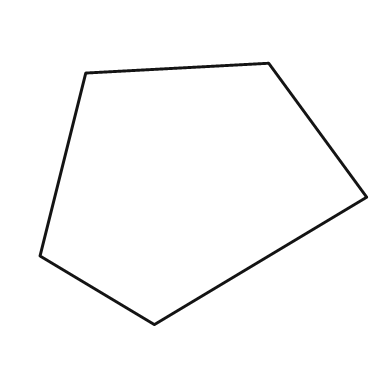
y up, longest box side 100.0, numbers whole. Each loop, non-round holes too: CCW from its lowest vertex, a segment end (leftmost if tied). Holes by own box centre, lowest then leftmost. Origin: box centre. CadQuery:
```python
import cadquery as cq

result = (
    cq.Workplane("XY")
    .moveTo(-15.0, -40.0)
    .lineTo(50.0, -1.0)
    .lineTo(20.0, 40.0)
    .lineTo(-36.0, 37.0)
    .lineTo(-50.0, -19.0)
    .close()
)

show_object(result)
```